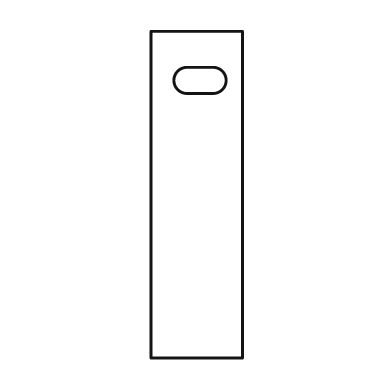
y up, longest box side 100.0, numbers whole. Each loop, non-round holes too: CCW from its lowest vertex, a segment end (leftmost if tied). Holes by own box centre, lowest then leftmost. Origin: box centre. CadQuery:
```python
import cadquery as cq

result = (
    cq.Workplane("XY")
    .moveTo(-14.0, -50.0)
    .lineTo(14.0, -50.0)
    .lineTo(14.0, 50.0)
    .lineTo(-14.0, 50.0)
    .close()
    .moveTo(-3.0, 31.0)
    .lineTo(5.0, 31.0)
    .threePointArc((9.0, 35.0), (5.0, 39.0))
    .lineTo(-3.0, 39.0)
    .threePointArc((-7.0, 35.0), (-3.0, 31.0))
    .close()
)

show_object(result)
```